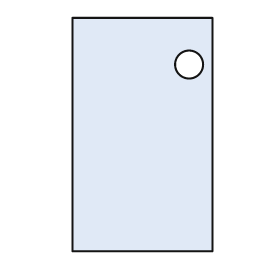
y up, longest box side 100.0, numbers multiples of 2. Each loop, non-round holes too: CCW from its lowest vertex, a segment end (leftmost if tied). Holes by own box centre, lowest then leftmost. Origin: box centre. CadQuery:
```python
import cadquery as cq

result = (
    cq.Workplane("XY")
    .moveTo(-30.0, -50.0)
    .lineTo(30.0, -50.0)
    .lineTo(30.0, 50.0)
    .lineTo(-30.0, 50.0)
    .close()
    .moveTo(20.0, 30.0)
    .circle(6.0)
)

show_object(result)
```